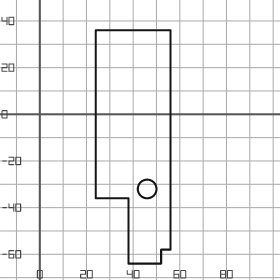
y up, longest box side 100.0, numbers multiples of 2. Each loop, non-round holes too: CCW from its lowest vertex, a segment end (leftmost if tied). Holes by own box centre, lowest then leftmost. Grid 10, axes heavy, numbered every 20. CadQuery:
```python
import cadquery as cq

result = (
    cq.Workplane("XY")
    .moveTo(38.0, -64.0)
    .lineTo(52.0, -64.0)
    .lineTo(52.0, -58.0)
    .lineTo(56.0, -58.0)
    .lineTo(56.0, 36.0)
    .lineTo(24.0, 36.0)
    .lineTo(24.0, -36.0)
    .lineTo(38.0, -36.0)
    .close()
    .moveTo(46.0, -32.0)
    .circle(4.0)
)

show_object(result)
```